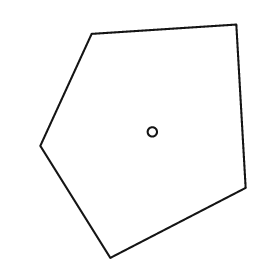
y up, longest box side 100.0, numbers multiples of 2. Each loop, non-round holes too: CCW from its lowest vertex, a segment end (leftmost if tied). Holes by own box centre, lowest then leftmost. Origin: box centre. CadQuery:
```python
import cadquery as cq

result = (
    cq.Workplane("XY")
    .moveTo(-14.0, -50.0)
    .lineTo(44.0, -20.0)
    .lineTo(40.0, 50.0)
    .lineTo(-22.0, 46.0)
    .lineTo(-44.0, -2.0)
    .close()
    .moveTo(4.0, 4.0)
    .circle(2.0)
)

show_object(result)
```